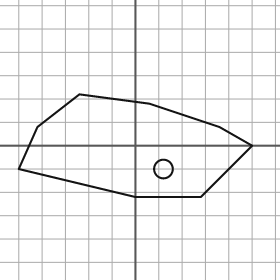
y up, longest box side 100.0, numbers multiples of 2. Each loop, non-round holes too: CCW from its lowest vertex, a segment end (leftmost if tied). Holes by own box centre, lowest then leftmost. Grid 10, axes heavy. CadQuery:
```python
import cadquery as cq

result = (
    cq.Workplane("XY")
    .moveTo(0.0, -22.0)
    .lineTo(28.0, -22.0)
    .lineTo(50.0, 0.0)
    .lineTo(36.0, 8.0)
    .lineTo(6.0, 18.0)
    .lineTo(-24.0, 22.0)
    .lineTo(-42.0, 8.0)
    .lineTo(-50.0, -10.0)
    .close()
    .moveTo(12.0, -10.0)
    .circle(4.0)
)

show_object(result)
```